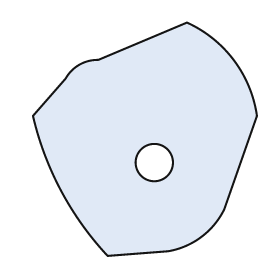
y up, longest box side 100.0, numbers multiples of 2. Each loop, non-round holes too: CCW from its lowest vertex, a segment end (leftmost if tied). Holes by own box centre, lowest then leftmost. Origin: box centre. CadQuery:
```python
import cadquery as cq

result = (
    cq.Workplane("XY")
    .moveTo(-16.0, -50.0)
    .lineTo(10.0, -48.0)
    .threePointArc((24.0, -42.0), (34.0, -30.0))
    .lineTo(48.0, 10.0)
    .threePointArc((38.0, 34.0), (18.0, 50.0))
    .lineTo(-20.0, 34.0)
    .threePointArc((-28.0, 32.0), (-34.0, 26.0))
    .lineTo(-48.0, 10.0)
    .threePointArc((-36.0, -22.0), (-16.0, -50.0))
    .close()
    .moveTo(4.0, -10.0)
    .circle(8.0)
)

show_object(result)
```